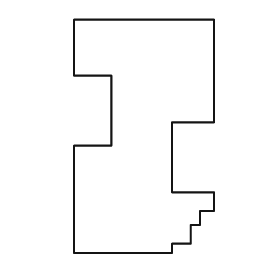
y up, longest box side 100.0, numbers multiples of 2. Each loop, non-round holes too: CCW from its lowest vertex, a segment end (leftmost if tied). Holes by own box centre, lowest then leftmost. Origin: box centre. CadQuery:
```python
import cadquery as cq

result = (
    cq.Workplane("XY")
    .moveTo(-30.0, -50.0)
    .lineTo(12.0, -50.0)
    .lineTo(12.0, -46.0)
    .lineTo(20.0, -46.0)
    .lineTo(20.0, -38.0)
    .lineTo(24.0, -38.0)
    .lineTo(24.0, -32.0)
    .lineTo(30.0, -32.0)
    .lineTo(30.0, -24.0)
    .lineTo(12.0, -24.0)
    .lineTo(12.0, 6.0)
    .lineTo(30.0, 6.0)
    .lineTo(30.0, 50.0)
    .lineTo(-30.0, 50.0)
    .lineTo(-30.0, 26.0)
    .lineTo(-14.0, 26.0)
    .lineTo(-14.0, -4.0)
    .lineTo(-30.0, -4.0)
    .close()
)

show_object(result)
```